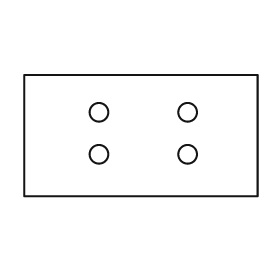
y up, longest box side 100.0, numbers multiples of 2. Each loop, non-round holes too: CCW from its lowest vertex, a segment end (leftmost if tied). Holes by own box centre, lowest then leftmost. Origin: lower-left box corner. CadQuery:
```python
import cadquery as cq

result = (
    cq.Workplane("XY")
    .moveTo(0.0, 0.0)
    .lineTo(100.0, 0.0)
    .lineTo(100.0, 52.0)
    .lineTo(0.0, 52.0)
    .close()
    .moveTo(32.0, 18.0)
    .circle(4.0)
    .moveTo(70.0, 18.0)
    .circle(4.0)
    .moveTo(32.0, 36.0)
    .circle(4.0)
    .moveTo(70.0, 36.0)
    .circle(4.0)
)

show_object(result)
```